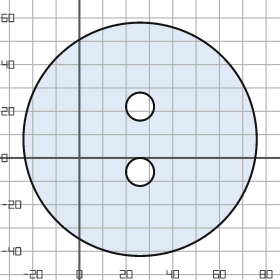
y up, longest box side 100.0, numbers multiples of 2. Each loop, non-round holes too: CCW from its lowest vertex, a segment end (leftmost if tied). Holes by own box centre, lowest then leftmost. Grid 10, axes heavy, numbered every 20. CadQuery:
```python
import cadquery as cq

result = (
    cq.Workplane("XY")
    .moveTo(26.0, 8.0)
    .circle(50.0)
    .moveTo(26.0, -6.0)
    .circle(6.0)
    .moveTo(26.0, 22.0)
    .circle(6.0)
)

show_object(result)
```